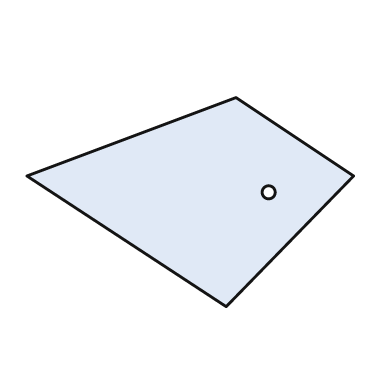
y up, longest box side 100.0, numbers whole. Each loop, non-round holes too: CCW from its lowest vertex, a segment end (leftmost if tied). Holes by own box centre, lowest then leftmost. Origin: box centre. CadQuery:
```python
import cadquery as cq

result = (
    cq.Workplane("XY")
    .moveTo(11.0, -32.0)
    .lineTo(50.0, 8.0)
    .lineTo(14.0, 32.0)
    .lineTo(-50.0, 8.0)
    .close()
    .moveTo(24.0, 3.0)
    .circle(2.0)
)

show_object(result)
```